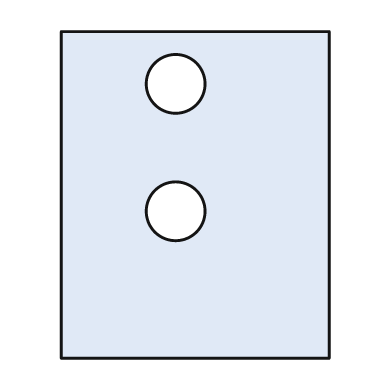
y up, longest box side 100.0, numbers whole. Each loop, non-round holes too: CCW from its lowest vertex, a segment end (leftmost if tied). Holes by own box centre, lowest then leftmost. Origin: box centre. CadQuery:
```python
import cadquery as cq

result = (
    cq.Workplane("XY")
    .moveTo(-41.0, -50.0)
    .lineTo(41.0, -50.0)
    .lineTo(41.0, 50.0)
    .lineTo(-41.0, 50.0)
    .close()
    .moveTo(-6.0, -5.0)
    .circle(9.0)
    .moveTo(-6.0, 34.0)
    .circle(9.0)
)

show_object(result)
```